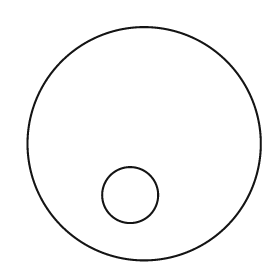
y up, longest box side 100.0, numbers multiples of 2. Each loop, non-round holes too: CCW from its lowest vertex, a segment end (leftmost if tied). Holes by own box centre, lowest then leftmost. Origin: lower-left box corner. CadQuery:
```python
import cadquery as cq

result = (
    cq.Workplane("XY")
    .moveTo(50.0, 50.0)
    .circle(50.0)
    .moveTo(44.0, 28.0)
    .circle(12.0)
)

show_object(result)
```